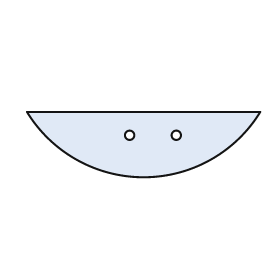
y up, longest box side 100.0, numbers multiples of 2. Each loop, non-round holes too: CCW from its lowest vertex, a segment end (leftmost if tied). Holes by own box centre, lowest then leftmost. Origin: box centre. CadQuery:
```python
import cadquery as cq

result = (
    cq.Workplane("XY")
    .moveTo(-50.0, 14.0)
    .threePointArc((0.0, -14.0), (50.0, 14.0))
    .close()
    .moveTo(-6.0, 4.0)
    .circle(2.0)
    .moveTo(14.0, 4.0)
    .circle(2.0)
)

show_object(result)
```